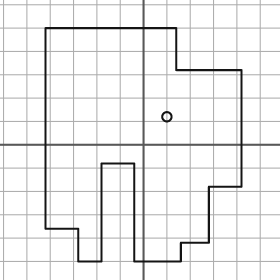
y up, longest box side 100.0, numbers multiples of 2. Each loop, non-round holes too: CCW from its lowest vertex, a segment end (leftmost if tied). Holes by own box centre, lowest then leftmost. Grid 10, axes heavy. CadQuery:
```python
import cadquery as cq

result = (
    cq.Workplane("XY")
    .moveTo(-28.0, -50.0)
    .lineTo(-18.0, -50.0)
    .lineTo(-18.0, -8.0)
    .lineTo(-4.0, -8.0)
    .lineTo(-4.0, -50.0)
    .lineTo(16.0, -50.0)
    .lineTo(16.0, -42.0)
    .lineTo(28.0, -42.0)
    .lineTo(28.0, -18.0)
    .lineTo(42.0, -18.0)
    .lineTo(42.0, 32.0)
    .lineTo(14.0, 32.0)
    .lineTo(14.0, 50.0)
    .lineTo(-42.0, 50.0)
    .lineTo(-42.0, -36.0)
    .lineTo(-28.0, -36.0)
    .close()
    .moveTo(10.0, 12.0)
    .circle(2.0)
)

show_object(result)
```